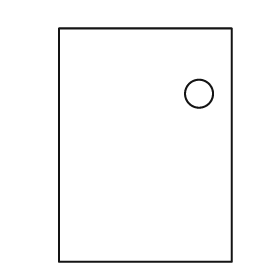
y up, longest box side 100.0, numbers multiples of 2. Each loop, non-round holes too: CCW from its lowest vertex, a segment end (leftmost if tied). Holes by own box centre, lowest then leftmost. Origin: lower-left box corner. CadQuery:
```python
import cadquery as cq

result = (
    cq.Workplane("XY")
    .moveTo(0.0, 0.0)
    .lineTo(74.0, 0.0)
    .lineTo(74.0, 100.0)
    .lineTo(0.0, 100.0)
    .close()
    .moveTo(60.0, 72.0)
    .circle(6.0)
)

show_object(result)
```